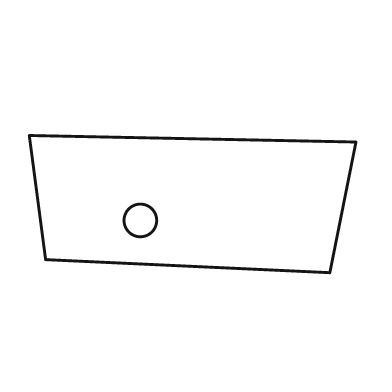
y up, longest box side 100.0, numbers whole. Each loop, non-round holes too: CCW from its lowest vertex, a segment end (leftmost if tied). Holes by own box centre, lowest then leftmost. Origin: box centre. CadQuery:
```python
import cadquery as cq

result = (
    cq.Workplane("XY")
    .moveTo(42.0, -21.0)
    .lineTo(50.0, 19.0)
    .lineTo(-50.0, 21.0)
    .lineTo(-45.0, -17.0)
    .close()
    .moveTo(-16.0, -5.0)
    .circle(5.0)
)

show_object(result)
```